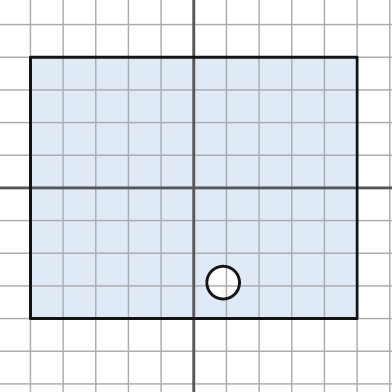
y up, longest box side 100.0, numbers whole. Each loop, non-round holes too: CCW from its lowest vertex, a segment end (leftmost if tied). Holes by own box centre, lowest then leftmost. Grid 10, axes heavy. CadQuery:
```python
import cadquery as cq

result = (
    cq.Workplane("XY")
    .moveTo(-50.0, -40.0)
    .lineTo(50.0, -40.0)
    .lineTo(50.0, 40.0)
    .lineTo(-50.0, 40.0)
    .close()
    .moveTo(9.0, -29.0)
    .circle(5.0)
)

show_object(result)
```